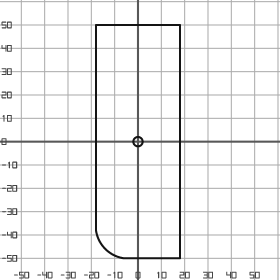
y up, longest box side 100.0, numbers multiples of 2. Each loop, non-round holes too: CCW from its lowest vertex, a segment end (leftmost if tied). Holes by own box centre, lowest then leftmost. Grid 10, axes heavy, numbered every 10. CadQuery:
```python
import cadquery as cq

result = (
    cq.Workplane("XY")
    .moveTo(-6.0, -50.0)
    .lineTo(18.0, -50.0)
    .lineTo(18.0, 50.0)
    .lineTo(-18.0, 50.0)
    .lineTo(-18.0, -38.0)
    .threePointArc((-14.0, -46.0), (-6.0, -50.0))
    .close()
    .moveTo(0.0, 0.0)
    .circle(2.0)
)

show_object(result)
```